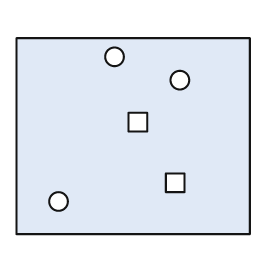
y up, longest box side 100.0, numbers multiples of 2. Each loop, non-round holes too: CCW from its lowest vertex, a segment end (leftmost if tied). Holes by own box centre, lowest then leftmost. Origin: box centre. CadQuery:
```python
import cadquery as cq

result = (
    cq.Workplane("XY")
    .moveTo(-50.0, -42.0)
    .lineTo(50.0, -42.0)
    .lineTo(50.0, 42.0)
    .lineTo(-50.0, 42.0)
    .close()
    .moveTo(-32.0, -28.0)
    .circle(4.0)
    .moveTo(14.0, -24.0)
    .lineTo(22.0, -24.0)
    .lineTo(22.0, -16.0)
    .lineTo(14.0, -16.0)
    .close()
    .moveTo(-2.0, 2.0)
    .lineTo(6.0, 2.0)
    .lineTo(6.0, 10.0)
    .lineTo(-2.0, 10.0)
    .close()
    .moveTo(20.0, 24.0)
    .circle(4.0)
    .moveTo(-8.0, 34.0)
    .circle(4.0)
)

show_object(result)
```